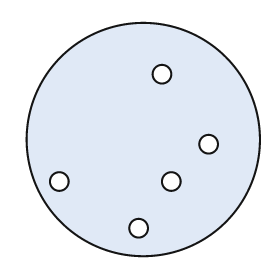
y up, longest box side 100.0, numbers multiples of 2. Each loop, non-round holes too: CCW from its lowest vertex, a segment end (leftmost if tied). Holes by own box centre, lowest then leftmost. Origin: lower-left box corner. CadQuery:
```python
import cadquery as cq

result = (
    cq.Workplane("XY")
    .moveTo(50.0, 50.0)
    .circle(50.0)
    .moveTo(48.0, 12.0)
    .circle(4.0)
    .moveTo(14.0, 32.0)
    .circle(4.0)
    .moveTo(62.0, 32.0)
    .circle(4.0)
    .moveTo(78.0, 48.0)
    .circle(4.0)
    .moveTo(58.0, 78.0)
    .circle(4.0)
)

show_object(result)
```